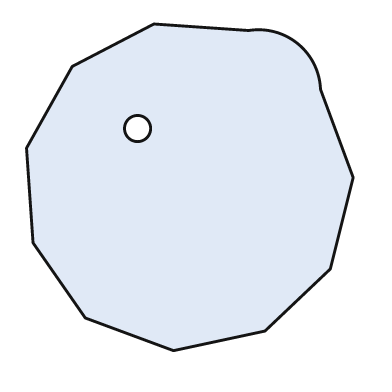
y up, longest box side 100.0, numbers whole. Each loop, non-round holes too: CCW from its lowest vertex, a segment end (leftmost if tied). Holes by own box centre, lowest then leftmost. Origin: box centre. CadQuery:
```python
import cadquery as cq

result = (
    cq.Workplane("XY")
    .moveTo(-5.0, -50.0)
    .lineTo(23.0, -44.0)
    .lineTo(43.0, -25.0)
    .lineTo(50.0, 3.0)
    .lineTo(40.0, 30.0)
    .threePointArc((33.0, 44.0), (18.0, 48.0))
    .lineTo(-11.0, 50.0)
    .lineTo(-36.0, 37.0)
    .lineTo(-50.0, 12.0)
    .lineTo(-48.0, -17.0)
    .lineTo(-32.0, -40.0)
    .close()
    .moveTo(-16.0, 18.0)
    .circle(4.0)
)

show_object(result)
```